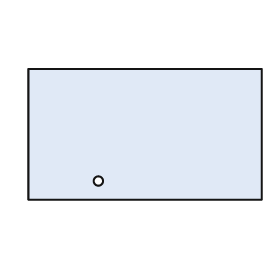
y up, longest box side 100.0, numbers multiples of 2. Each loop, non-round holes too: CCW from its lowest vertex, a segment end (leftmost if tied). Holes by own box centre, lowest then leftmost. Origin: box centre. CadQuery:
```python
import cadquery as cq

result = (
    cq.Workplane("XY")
    .moveTo(-50.0, -28.0)
    .lineTo(50.0, -28.0)
    .lineTo(50.0, 28.0)
    .lineTo(-50.0, 28.0)
    .close()
    .moveTo(-20.0, -20.0)
    .circle(2.0)
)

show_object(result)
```